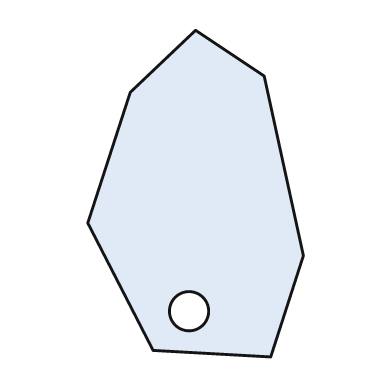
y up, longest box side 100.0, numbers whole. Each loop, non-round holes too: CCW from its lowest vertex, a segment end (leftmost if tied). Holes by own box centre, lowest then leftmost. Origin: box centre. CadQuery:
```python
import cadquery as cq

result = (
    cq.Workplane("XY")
    .moveTo(23.0, -50.0)
    .lineTo(33.0, -19.0)
    .lineTo(21.0, 36.0)
    .lineTo(0.0, 50.0)
    .lineTo(-20.0, 31.0)
    .lineTo(-33.0, -9.0)
    .lineTo(-13.0, -48.0)
    .close()
    .moveTo(-2.0, -36.0)
    .circle(6.0)
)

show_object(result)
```